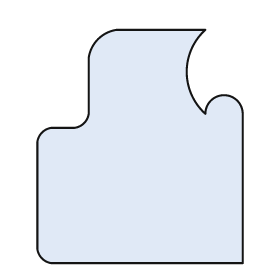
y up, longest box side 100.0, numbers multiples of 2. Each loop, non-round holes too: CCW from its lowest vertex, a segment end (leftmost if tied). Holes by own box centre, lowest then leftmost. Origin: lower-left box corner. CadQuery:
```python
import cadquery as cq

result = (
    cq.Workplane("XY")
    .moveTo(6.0, 0.0)
    .lineTo(88.0, 0.0)
    .lineTo(88.0, 64.0)
    .threePointArc((80.0, 72.0), (72.0, 64.0))
    .threePointArc((64.0, 82.0), (72.0, 100.0))
    .lineTo(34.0, 100.0)
    .threePointArc((26.0, 96.0), (22.0, 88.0))
    .lineTo(22.0, 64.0)
    .threePointArc((20.0, 60.0), (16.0, 58.0))
    .lineTo(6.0, 58.0)
    .threePointArc((2.0, 56.0), (0.0, 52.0))
    .lineTo(0.0, 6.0)
    .threePointArc((2.0, 2.0), (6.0, 0.0))
    .close()
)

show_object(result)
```